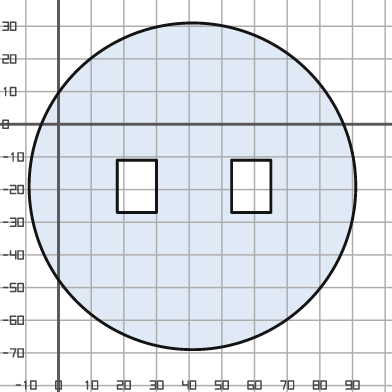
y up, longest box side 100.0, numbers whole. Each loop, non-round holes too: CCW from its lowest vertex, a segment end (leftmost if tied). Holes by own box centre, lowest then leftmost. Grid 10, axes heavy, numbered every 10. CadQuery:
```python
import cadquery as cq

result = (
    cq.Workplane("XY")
    .moveTo(41.0, -19.0)
    .circle(50.0)
    .moveTo(18.0, -27.0)
    .lineTo(30.0, -27.0)
    .lineTo(30.0, -11.0)
    .lineTo(18.0, -11.0)
    .close()
    .moveTo(53.0, -27.0)
    .lineTo(65.0, -27.0)
    .lineTo(65.0, -11.0)
    .lineTo(53.0, -11.0)
    .close()
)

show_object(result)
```